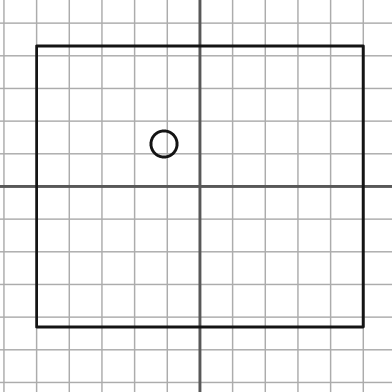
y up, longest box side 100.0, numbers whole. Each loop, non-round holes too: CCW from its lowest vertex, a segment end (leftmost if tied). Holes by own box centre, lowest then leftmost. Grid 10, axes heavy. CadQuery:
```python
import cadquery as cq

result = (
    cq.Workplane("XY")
    .moveTo(-50.0, -43.0)
    .lineTo(50.0, -43.0)
    .lineTo(50.0, 43.0)
    .lineTo(-50.0, 43.0)
    .close()
    .moveTo(-11.0, 13.0)
    .circle(4.0)
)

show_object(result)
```